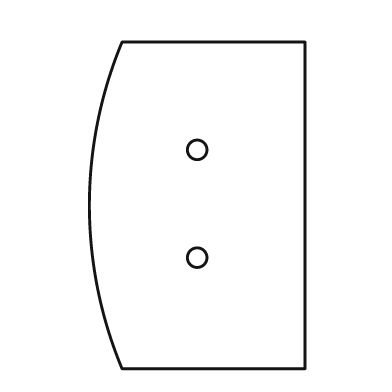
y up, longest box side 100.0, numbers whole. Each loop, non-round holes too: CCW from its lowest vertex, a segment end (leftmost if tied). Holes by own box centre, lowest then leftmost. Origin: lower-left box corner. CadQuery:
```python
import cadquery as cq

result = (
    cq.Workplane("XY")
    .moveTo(10.0, 0.0)
    .lineTo(66.0, 0.0)
    .lineTo(66.0, 100.0)
    .lineTo(10.0, 100.0)
    .threePointArc((0.0, 50.0), (10.0, 0.0))
    .close()
    .moveTo(33.0, 34.0)
    .circle(3.0)
    .moveTo(33.0, 67.0)
    .circle(3.0)
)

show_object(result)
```